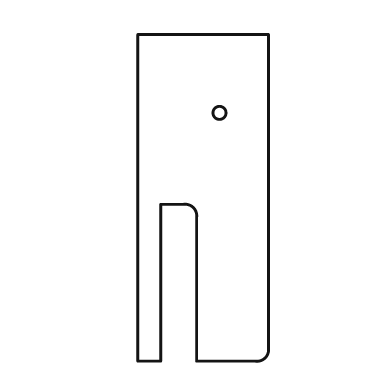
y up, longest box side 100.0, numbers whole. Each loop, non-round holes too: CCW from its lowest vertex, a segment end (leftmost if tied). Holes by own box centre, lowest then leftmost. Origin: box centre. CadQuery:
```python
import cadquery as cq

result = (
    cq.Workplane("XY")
    .moveTo(-20.0, -50.0)
    .lineTo(-13.0, -50.0)
    .lineTo(-13.0, -2.0)
    .lineTo(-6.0, -2.0)
    .threePointArc((-3.0, -3.0), (-2.0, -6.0))
    .lineTo(-2.0, -50.0)
    .lineTo(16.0, -50.0)
    .threePointArc((19.0, -49.0), (20.0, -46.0))
    .lineTo(20.0, 50.0)
    .lineTo(-20.0, 50.0)
    .close()
    .moveTo(5.0, 26.0)
    .circle(2.0)
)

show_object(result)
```